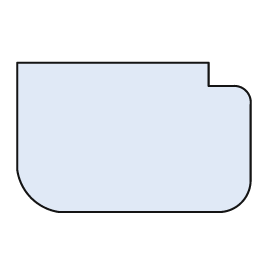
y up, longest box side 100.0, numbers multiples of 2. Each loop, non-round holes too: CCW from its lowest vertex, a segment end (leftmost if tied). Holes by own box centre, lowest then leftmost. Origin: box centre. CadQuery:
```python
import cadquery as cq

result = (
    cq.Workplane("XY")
    .moveTo(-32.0, -32.0)
    .lineTo(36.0, -32.0)
    .threePointArc((46.0, -28.0), (50.0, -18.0))
    .lineTo(50.0, 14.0)
    .threePointArc((48.0, 20.0), (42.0, 22.0))
    .lineTo(32.0, 22.0)
    .lineTo(32.0, 32.0)
    .lineTo(-50.0, 32.0)
    .lineTo(-50.0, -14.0)
    .threePointArc((-44.0, -26.0), (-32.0, -32.0))
    .close()
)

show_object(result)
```